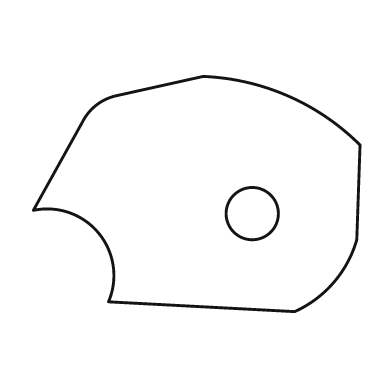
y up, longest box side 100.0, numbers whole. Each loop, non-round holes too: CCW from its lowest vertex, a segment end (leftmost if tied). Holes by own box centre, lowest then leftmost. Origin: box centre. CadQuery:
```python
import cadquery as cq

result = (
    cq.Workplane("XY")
    .moveTo(30.0, -36.0)
    .threePointArc((42.0, -27.0), (49.0, -14.0))
    .lineTo(50.0, 15.0)
    .threePointArc((28.0, 30.0), (2.0, 36.0))
    .lineTo(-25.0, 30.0)
    .threePointArc((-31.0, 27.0), (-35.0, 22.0))
    .lineTo(-50.0, -5.0)
    .threePointArc((-30.0, -12.0), (-27.0, -33.0))
    .close()
    .moveTo(17.0, -6.0)
    .circle(8.0)
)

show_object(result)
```